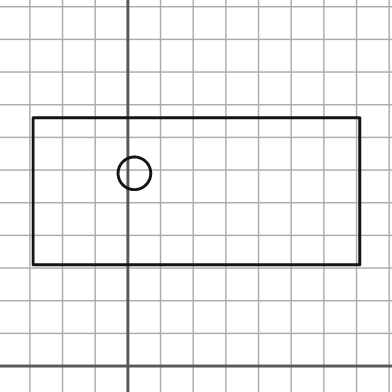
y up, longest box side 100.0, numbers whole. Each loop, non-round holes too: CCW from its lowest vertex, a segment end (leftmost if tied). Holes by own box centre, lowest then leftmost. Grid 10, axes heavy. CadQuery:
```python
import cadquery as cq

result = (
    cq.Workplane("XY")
    .moveTo(-29.0, 31.0)
    .lineTo(71.0, 31.0)
    .lineTo(71.0, 76.0)
    .lineTo(-29.0, 76.0)
    .close()
    .moveTo(2.0, 59.0)
    .circle(5.0)
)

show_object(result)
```